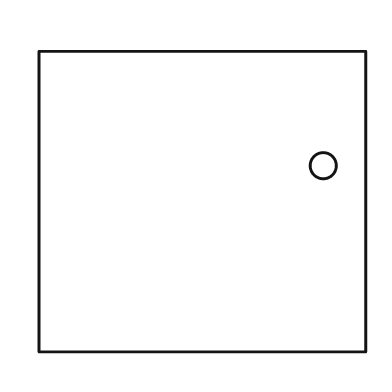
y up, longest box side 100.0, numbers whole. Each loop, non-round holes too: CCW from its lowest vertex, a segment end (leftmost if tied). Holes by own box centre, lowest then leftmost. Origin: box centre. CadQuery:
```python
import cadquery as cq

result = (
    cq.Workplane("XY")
    .moveTo(-50.0, -46.0)
    .lineTo(50.0, -46.0)
    .lineTo(50.0, 46.0)
    .lineTo(-50.0, 46.0)
    .close()
    .moveTo(37.0, 11.0)
    .circle(4.0)
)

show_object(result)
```